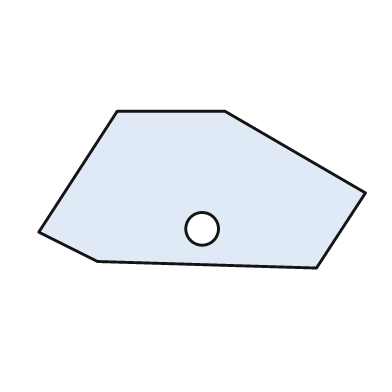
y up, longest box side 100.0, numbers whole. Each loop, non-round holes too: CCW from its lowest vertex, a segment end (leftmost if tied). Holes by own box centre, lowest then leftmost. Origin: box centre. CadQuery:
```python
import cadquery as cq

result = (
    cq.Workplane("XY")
    .moveTo(35.0, -24.0)
    .lineTo(50.0, -1.0)
    .lineTo(7.0, 24.0)
    .lineTo(-26.0, 24.0)
    .lineTo(-50.0, -13.0)
    .lineTo(-32.0, -22.0)
    .close()
    .moveTo(0.0, -12.0)
    .circle(5.0)
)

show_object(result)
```